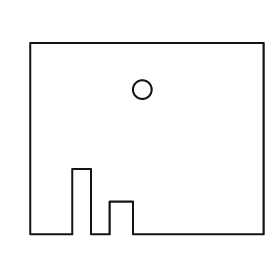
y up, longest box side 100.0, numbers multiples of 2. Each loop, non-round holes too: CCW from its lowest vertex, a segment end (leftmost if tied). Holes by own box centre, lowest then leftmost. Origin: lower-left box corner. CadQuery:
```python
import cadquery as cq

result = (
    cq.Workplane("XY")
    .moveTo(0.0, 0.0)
    .lineTo(18.0, 0.0)
    .lineTo(18.0, 28.0)
    .lineTo(26.0, 28.0)
    .lineTo(26.0, 0.0)
    .lineTo(34.0, 0.0)
    .lineTo(34.0, 14.0)
    .lineTo(44.0, 14.0)
    .lineTo(44.0, 0.0)
    .lineTo(100.0, 0.0)
    .lineTo(100.0, 82.0)
    .lineTo(0.0, 82.0)
    .close()
    .moveTo(48.0, 62.0)
    .circle(4.0)
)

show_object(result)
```